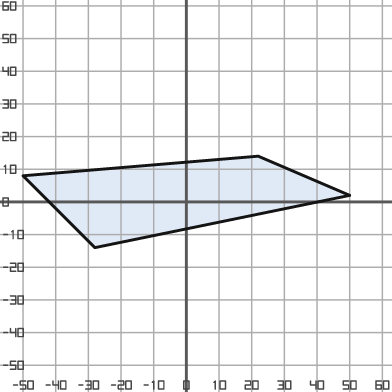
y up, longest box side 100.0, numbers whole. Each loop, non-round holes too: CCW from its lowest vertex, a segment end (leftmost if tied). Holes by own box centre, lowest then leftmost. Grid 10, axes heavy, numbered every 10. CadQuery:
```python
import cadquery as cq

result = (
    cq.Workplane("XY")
    .moveTo(-28.0, -14.0)
    .lineTo(50.0, 2.0)
    .lineTo(22.0, 14.0)
    .lineTo(-50.0, 8.0)
    .close()
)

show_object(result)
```